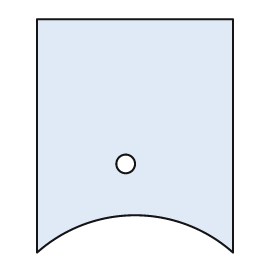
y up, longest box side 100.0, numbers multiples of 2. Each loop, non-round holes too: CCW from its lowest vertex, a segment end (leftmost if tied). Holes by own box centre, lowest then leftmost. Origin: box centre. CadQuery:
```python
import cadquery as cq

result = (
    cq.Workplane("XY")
    .moveTo(-42.0, -50.0)
    .threePointArc((0.0, -34.0), (42.0, -50.0))
    .lineTo(42.0, 50.0)
    .lineTo(-42.0, 50.0)
    .close()
    .moveTo(-4.0, -12.0)
    .circle(4.0)
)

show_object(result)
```